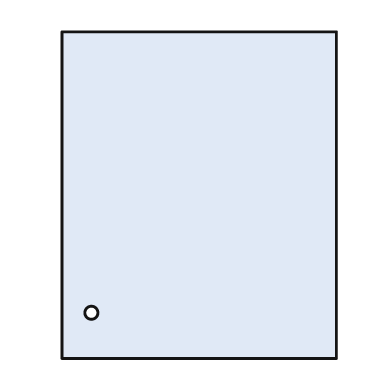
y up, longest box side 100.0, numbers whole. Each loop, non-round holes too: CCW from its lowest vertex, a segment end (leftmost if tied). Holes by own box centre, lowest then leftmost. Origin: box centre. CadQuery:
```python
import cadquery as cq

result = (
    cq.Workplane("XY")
    .moveTo(-42.0, -50.0)
    .lineTo(42.0, -50.0)
    .lineTo(42.0, 50.0)
    .lineTo(-42.0, 50.0)
    .close()
    .moveTo(-33.0, -36.0)
    .circle(2.0)
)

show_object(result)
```